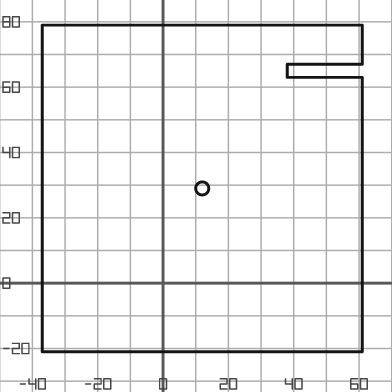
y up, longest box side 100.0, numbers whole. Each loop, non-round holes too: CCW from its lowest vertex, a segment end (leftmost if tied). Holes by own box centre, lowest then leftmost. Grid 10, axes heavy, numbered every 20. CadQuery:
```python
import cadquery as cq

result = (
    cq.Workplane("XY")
    .moveTo(-37.0, -21.0)
    .lineTo(61.0, -21.0)
    .lineTo(61.0, 63.0)
    .lineTo(38.0, 63.0)
    .lineTo(38.0, 67.0)
    .lineTo(61.0, 67.0)
    .lineTo(61.0, 79.0)
    .lineTo(-37.0, 79.0)
    .close()
    .moveTo(12.0, 29.0)
    .circle(2.0)
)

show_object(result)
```